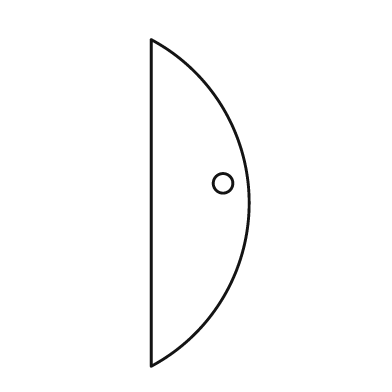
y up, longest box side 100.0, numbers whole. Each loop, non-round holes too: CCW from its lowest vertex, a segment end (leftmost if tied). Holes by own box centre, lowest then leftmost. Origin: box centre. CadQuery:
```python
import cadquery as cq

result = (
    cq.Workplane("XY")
    .moveTo(-15.0, -50.0)
    .threePointArc((15.0, 0.0), (-15.0, 50.0))
    .close()
    .moveTo(7.0, 6.0)
    .circle(3.0)
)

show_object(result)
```